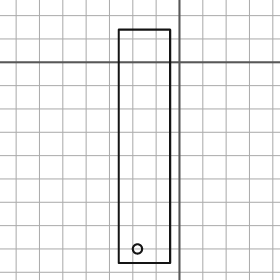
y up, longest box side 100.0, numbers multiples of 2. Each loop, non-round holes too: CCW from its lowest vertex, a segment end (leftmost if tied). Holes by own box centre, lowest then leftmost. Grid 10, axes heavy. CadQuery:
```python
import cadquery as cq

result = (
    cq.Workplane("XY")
    .moveTo(-26.0, -86.0)
    .lineTo(-4.0, -86.0)
    .lineTo(-4.0, 14.0)
    .lineTo(-26.0, 14.0)
    .close()
    .moveTo(-18.0, -80.0)
    .circle(2.0)
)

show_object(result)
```